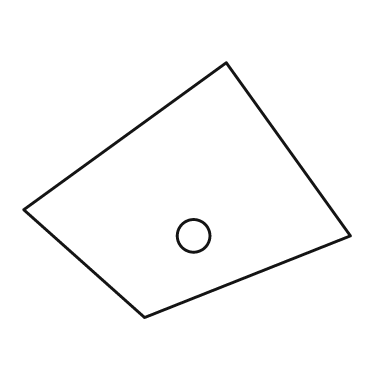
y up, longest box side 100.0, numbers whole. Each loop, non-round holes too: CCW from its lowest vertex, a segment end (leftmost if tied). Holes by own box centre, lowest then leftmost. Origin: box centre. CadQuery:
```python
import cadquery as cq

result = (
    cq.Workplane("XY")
    .moveTo(-13.0, -39.0)
    .lineTo(50.0, -14.0)
    .lineTo(12.0, 39.0)
    .lineTo(-50.0, -6.0)
    .close()
    .moveTo(2.0, -14.0)
    .circle(5.0)
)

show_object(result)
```